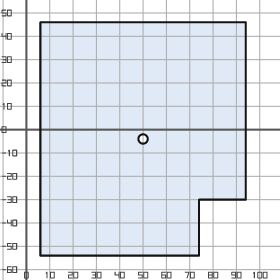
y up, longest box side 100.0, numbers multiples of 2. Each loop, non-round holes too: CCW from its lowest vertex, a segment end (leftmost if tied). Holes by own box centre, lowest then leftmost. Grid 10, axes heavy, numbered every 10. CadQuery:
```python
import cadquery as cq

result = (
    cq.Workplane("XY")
    .moveTo(6.0, -54.0)
    .lineTo(74.0, -54.0)
    .lineTo(74.0, -30.0)
    .lineTo(94.0, -30.0)
    .lineTo(94.0, 46.0)
    .lineTo(6.0, 46.0)
    .close()
    .moveTo(50.0, -4.0)
    .circle(2.0)
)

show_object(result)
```